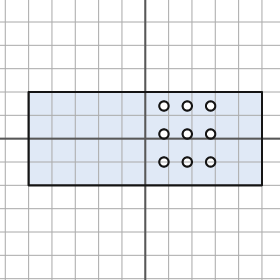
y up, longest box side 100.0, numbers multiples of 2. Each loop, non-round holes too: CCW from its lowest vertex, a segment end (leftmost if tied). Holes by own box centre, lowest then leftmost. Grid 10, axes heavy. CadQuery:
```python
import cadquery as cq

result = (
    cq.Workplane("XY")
    .moveTo(-50.0, -20.0)
    .lineTo(50.0, -20.0)
    .lineTo(50.0, 20.0)
    .lineTo(-50.0, 20.0)
    .close()
    .moveTo(8.0, -10.0)
    .circle(2.0)
    .moveTo(18.0, -10.0)
    .circle(2.0)
    .moveTo(28.0, -10.0)
    .circle(2.0)
    .moveTo(8.0, 2.0)
    .circle(2.0)
    .moveTo(18.0, 2.0)
    .circle(2.0)
    .moveTo(28.0, 2.0)
    .circle(2.0)
    .moveTo(8.0, 14.0)
    .circle(2.0)
    .moveTo(18.0, 14.0)
    .circle(2.0)
    .moveTo(28.0, 14.0)
    .circle(2.0)
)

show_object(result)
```